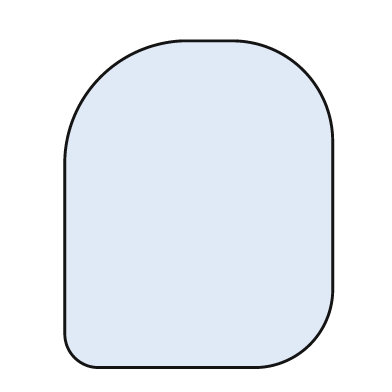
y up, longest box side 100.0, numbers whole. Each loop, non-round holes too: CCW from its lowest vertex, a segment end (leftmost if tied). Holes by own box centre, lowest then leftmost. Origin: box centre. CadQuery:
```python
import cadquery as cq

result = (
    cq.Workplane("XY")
    .moveTo(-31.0, -50.0)
    .lineTo(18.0, -50.0)
    .threePointArc((34.0, -43.0), (41.0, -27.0))
    .lineTo(41.0, 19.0)
    .threePointArc((32.0, 41.0), (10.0, 50.0))
    .lineTo(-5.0, 50.0)
    .threePointArc((-30.0, 39.0), (-41.0, 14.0))
    .lineTo(-41.0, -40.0)
    .threePointArc((-38.0, -47.0), (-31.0, -50.0))
    .close()
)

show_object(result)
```